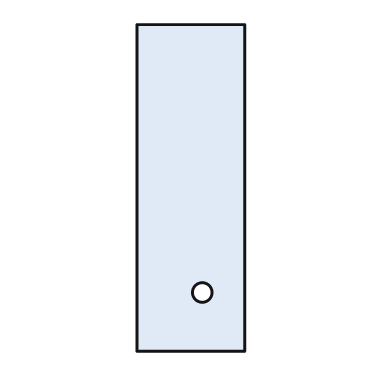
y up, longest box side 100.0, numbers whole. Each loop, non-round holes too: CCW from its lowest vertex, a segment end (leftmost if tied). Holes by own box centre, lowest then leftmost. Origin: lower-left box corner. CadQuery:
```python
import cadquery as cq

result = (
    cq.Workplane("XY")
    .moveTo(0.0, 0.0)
    .lineTo(33.0, 0.0)
    .lineTo(33.0, 100.0)
    .lineTo(0.0, 100.0)
    .close()
    .moveTo(20.0, 18.0)
    .circle(3.0)
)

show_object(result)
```